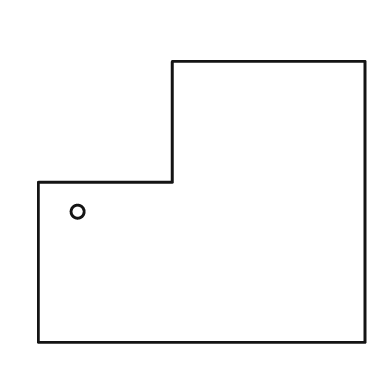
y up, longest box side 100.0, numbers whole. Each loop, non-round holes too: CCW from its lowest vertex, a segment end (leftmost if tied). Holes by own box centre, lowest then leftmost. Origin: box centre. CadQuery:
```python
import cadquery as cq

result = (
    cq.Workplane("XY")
    .moveTo(-50.0, -43.0)
    .lineTo(50.0, -43.0)
    .lineTo(50.0, 43.0)
    .lineTo(-9.0, 43.0)
    .lineTo(-9.0, 6.0)
    .lineTo(-50.0, 6.0)
    .close()
    .moveTo(-38.0, -3.0)
    .circle(2.0)
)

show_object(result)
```